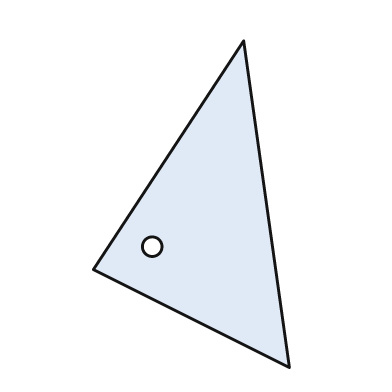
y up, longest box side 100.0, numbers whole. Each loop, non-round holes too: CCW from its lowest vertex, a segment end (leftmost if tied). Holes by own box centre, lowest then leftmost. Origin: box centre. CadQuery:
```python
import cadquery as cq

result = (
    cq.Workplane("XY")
    .moveTo(30.0, -50.0)
    .lineTo(16.0, 50.0)
    .lineTo(-30.0, -20.0)
    .close()
    .moveTo(-12.0, -13.0)
    .circle(3.0)
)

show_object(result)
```